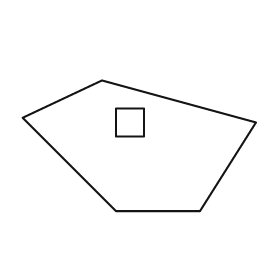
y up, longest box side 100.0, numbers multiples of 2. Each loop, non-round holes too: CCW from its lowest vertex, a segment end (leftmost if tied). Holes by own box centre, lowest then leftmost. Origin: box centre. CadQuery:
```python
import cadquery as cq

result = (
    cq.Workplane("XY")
    .moveTo(-10.0, -28.0)
    .lineTo(26.0, -28.0)
    .lineTo(50.0, 10.0)
    .lineTo(-16.0, 28.0)
    .lineTo(-50.0, 12.0)
    .close()
    .moveTo(-10.0, 4.0)
    .lineTo(2.0, 4.0)
    .lineTo(2.0, 16.0)
    .lineTo(-10.0, 16.0)
    .close()
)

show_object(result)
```